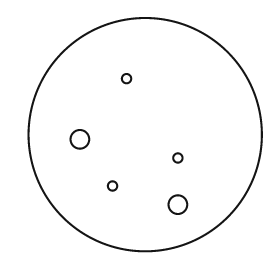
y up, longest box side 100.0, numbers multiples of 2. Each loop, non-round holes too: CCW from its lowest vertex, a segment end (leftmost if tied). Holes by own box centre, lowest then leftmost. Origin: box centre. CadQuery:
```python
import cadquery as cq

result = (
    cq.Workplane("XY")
    .moveTo(0.0, 0.0)
    .circle(50.0)
    .moveTo(14.0, -30.0)
    .circle(4.0)
    .moveTo(-14.0, -22.0)
    .circle(2.0)
    .moveTo(14.0, -10.0)
    .circle(2.0)
    .moveTo(-28.0, -2.0)
    .circle(4.0)
    .moveTo(-8.0, 24.0)
    .circle(2.0)
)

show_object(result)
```